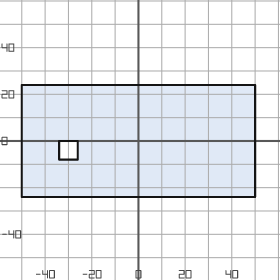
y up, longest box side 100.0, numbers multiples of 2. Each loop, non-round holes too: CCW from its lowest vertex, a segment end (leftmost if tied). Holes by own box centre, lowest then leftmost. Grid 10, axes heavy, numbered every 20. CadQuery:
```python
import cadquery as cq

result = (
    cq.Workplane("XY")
    .moveTo(-50.0, -24.0)
    .lineTo(50.0, -24.0)
    .lineTo(50.0, 24.0)
    .lineTo(-50.0, 24.0)
    .close()
    .moveTo(-34.0, -8.0)
    .lineTo(-26.0, -8.0)
    .lineTo(-26.0, 0.0)
    .lineTo(-34.0, 0.0)
    .close()
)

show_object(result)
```